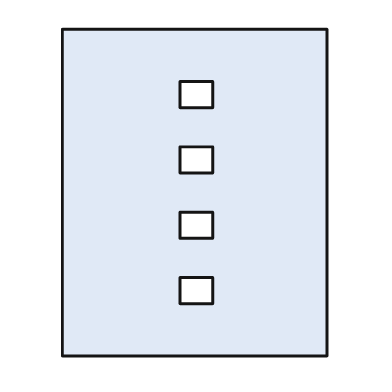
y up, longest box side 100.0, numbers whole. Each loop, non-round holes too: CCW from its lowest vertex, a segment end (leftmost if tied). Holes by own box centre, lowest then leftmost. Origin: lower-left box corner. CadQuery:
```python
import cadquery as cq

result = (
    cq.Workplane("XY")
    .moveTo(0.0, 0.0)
    .lineTo(81.0, 0.0)
    .lineTo(81.0, 100.0)
    .lineTo(0.0, 100.0)
    .close()
    .moveTo(36.0, 16.0)
    .lineTo(46.0, 16.0)
    .lineTo(46.0, 24.0)
    .lineTo(36.0, 24.0)
    .close()
    .moveTo(36.0, 36.0)
    .lineTo(46.0, 36.0)
    .lineTo(46.0, 44.0)
    .lineTo(36.0, 44.0)
    .close()
    .moveTo(36.0, 56.0)
    .lineTo(46.0, 56.0)
    .lineTo(46.0, 64.0)
    .lineTo(36.0, 64.0)
    .close()
    .moveTo(36.0, 76.0)
    .lineTo(46.0, 76.0)
    .lineTo(46.0, 84.0)
    .lineTo(36.0, 84.0)
    .close()
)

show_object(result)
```